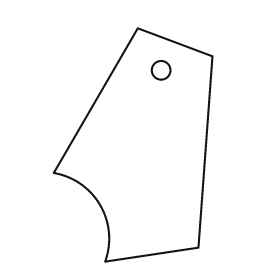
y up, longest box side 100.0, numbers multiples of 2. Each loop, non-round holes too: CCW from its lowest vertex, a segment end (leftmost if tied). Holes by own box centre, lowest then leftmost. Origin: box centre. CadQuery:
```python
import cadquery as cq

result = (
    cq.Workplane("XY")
    .moveTo(-12.0, -50.0)
    .lineTo(28.0, -44.0)
    .lineTo(34.0, 38.0)
    .lineTo(2.0, 50.0)
    .lineTo(-34.0, -12.0)
    .threePointArc((-14.0, -26.0), (-12.0, -50.0))
    .close()
    .moveTo(12.0, 32.0)
    .circle(4.0)
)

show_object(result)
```